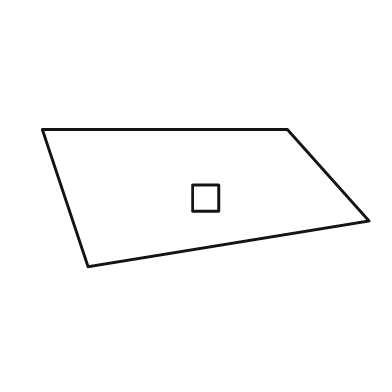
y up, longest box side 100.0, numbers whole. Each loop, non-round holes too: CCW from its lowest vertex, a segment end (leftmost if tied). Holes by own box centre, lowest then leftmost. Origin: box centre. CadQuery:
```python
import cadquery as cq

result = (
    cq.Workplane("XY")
    .moveTo(-36.0, -21.0)
    .lineTo(50.0, -7.0)
    .lineTo(25.0, 21.0)
    .lineTo(-50.0, 21.0)
    .close()
    .moveTo(-4.0, -4.0)
    .lineTo(4.0, -4.0)
    .lineTo(4.0, 4.0)
    .lineTo(-4.0, 4.0)
    .close()
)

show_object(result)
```